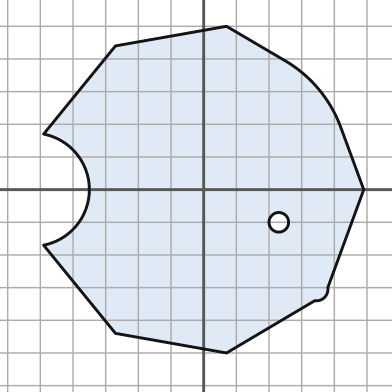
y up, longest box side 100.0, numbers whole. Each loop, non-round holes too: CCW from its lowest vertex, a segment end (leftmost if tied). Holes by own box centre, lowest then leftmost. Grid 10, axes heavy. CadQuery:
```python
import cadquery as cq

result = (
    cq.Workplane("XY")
    .moveTo(7.0, -50.0)
    .lineTo(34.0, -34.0)
    .threePointArc((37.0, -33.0), (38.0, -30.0))
    .lineTo(49.0, 0.0)
    .lineTo(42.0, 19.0)
    .threePointArc((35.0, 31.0), (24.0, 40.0))
    .lineTo(7.0, 50.0)
    .lineTo(-27.0, 44.0)
    .lineTo(-49.0, 17.0)
    .threePointArc((-35.0, 0.0), (-49.0, -17.0))
    .lineTo(-27.0, -44.0)
    .close()
    .moveTo(23.0, -10.0)
    .circle(3.0)
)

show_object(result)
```